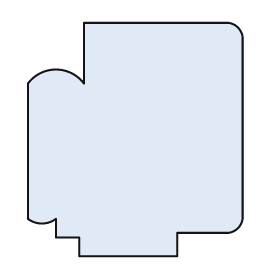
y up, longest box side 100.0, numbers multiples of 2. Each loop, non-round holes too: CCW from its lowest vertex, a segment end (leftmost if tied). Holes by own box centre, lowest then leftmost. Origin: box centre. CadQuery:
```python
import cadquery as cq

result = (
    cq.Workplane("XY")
    .moveTo(-24.0, -50.0)
    .lineTo(18.0, -50.0)
    .lineTo(18.0, -40.0)
    .lineTo(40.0, -40.0)
    .threePointArc((44.0, -38.0), (46.0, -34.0))
    .lineTo(46.0, 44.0)
    .threePointArc((44.0, 48.0), (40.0, 50.0))
    .lineTo(-22.0, 50.0)
    .lineTo(-22.0, 24.0)
    .threePointArc((-34.0, 30.0), (-46.0, 24.0))
    .lineTo(-46.0, -34.0)
    .threePointArc((-40.0, -36.0), (-34.0, -34.0))
    .lineTo(-34.0, -42.0)
    .lineTo(-24.0, -42.0)
    .close()
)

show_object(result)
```